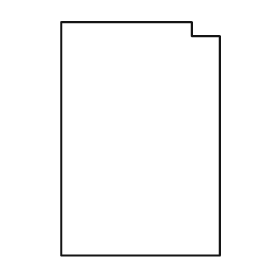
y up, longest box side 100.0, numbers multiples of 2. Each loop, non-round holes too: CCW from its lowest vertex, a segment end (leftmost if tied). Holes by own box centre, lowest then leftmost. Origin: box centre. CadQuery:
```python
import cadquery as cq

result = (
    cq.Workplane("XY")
    .moveTo(-34.0, -50.0)
    .lineTo(34.0, -50.0)
    .lineTo(34.0, 44.0)
    .lineTo(22.0, 44.0)
    .lineTo(22.0, 50.0)
    .lineTo(-34.0, 50.0)
    .close()
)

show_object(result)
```